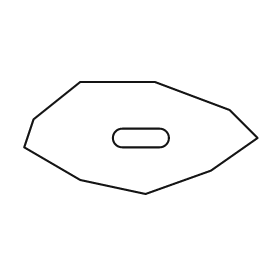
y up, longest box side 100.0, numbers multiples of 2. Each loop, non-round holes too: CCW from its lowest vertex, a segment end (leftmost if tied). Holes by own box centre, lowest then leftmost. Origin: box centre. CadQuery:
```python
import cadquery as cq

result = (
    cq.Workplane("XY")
    .moveTo(2.0, -24.0)
    .lineTo(30.0, -14.0)
    .lineTo(50.0, 0.0)
    .lineTo(38.0, 12.0)
    .lineTo(6.0, 24.0)
    .lineTo(-26.0, 24.0)
    .lineTo(-46.0, 8.0)
    .lineTo(-50.0, -4.0)
    .lineTo(-26.0, -18.0)
    .close()
    .moveTo(-8.0, -4.0)
    .lineTo(8.0, -4.0)
    .threePointArc((12.0, 0.0), (8.0, 4.0))
    .lineTo(-8.0, 4.0)
    .threePointArc((-12.0, 0.0), (-8.0, -4.0))
    .close()
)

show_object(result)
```